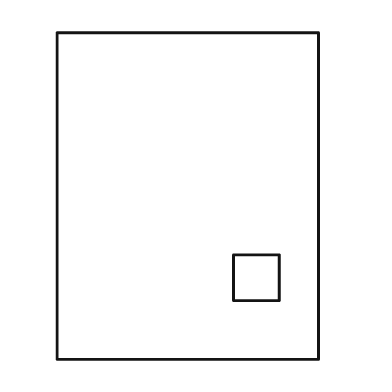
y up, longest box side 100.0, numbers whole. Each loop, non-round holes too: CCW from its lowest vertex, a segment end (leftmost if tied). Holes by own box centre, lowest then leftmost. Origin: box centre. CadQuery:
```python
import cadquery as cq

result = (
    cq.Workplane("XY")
    .moveTo(-40.0, -50.0)
    .lineTo(40.0, -50.0)
    .lineTo(40.0, 50.0)
    .lineTo(-40.0, 50.0)
    .close()
    .moveTo(14.0, -32.0)
    .lineTo(28.0, -32.0)
    .lineTo(28.0, -18.0)
    .lineTo(14.0, -18.0)
    .close()
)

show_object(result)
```